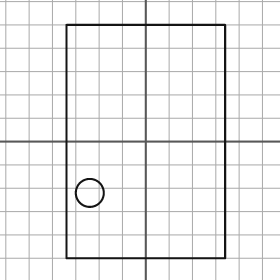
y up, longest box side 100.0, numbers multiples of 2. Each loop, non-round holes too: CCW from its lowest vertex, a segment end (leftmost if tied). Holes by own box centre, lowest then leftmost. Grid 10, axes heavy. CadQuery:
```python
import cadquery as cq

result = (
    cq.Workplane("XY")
    .moveTo(-34.0, -50.0)
    .lineTo(34.0, -50.0)
    .lineTo(34.0, 50.0)
    .lineTo(-34.0, 50.0)
    .close()
    .moveTo(-24.0, -22.0)
    .circle(6.0)
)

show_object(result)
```